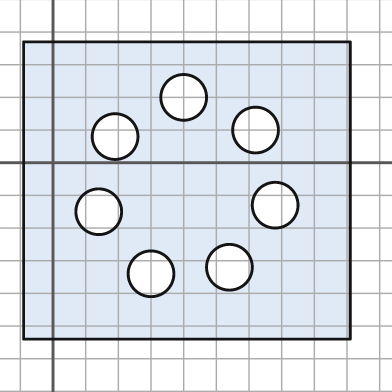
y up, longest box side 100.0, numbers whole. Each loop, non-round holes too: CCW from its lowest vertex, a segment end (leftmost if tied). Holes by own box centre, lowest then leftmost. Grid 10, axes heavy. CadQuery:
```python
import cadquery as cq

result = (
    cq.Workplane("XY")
    .moveTo(-9.0, -54.0)
    .lineTo(91.0, -54.0)
    .lineTo(91.0, 37.0)
    .lineTo(-9.0, 37.0)
    .close()
    .moveTo(30.0, -34.0)
    .circle(7.0)
    .moveTo(54.0, -32.0)
    .circle(7.0)
    .moveTo(14.0, -15.0)
    .circle(7.0)
    .moveTo(68.0, -13.0)
    .circle(7.0)
    .moveTo(19.0, 8.0)
    .circle(7.0)
    .moveTo(62.0, 10.0)
    .circle(7.0)
    .moveTo(40.0, 20.0)
    .circle(7.0)
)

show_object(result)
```